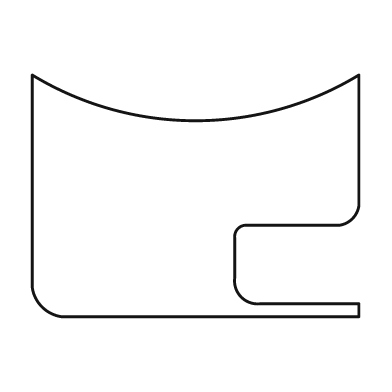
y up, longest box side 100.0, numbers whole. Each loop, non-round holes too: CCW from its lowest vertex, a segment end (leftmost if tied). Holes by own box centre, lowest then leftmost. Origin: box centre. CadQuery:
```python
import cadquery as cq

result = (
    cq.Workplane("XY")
    .moveTo(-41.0, -37.0)
    .lineTo(50.0, -37.0)
    .lineTo(50.0, -33.0)
    .lineTo(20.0, -33.0)
    .threePointArc((14.0, -31.0), (12.0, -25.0))
    .lineTo(12.0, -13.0)
    .threePointArc((13.0, -10.0), (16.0, -9.0))
    .lineTo(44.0, -9.0)
    .threePointArc((48.0, -7.0), (50.0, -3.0))
    .lineTo(50.0, 37.0)
    .threePointArc((0.0, 23.0), (-50.0, 37.0))
    .lineTo(-50.0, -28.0)
    .threePointArc((-47.0, -34.0), (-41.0, -37.0))
    .close()
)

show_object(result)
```